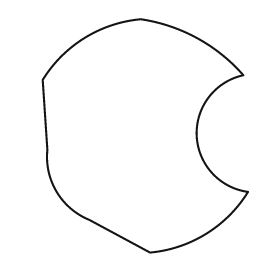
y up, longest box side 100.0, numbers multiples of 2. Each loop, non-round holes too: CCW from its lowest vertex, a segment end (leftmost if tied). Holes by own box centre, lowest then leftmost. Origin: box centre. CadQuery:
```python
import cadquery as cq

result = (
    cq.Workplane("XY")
    .moveTo(2.0, -50.0)
    .threePointArc((26.0, -42.0), (44.0, -24.0))
    .threePointArc((22.0, 0.0), (42.0, 26.0))
    .threePointArc((22.0, 42.0), (-2.0, 50.0))
    .threePointArc((-26.0, 42.0), (-44.0, 24.0))
    .lineTo(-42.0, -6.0)
    .threePointArc((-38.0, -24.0), (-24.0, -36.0))
    .close()
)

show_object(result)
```